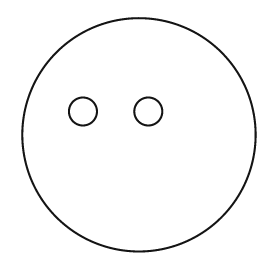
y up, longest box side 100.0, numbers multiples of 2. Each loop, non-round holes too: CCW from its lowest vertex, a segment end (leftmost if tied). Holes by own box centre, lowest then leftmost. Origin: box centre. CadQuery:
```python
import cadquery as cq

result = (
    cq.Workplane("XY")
    .moveTo(0.0, 0.0)
    .circle(50.0)
    .moveTo(-24.0, 10.0)
    .circle(6.0)
    .moveTo(4.0, 10.0)
    .circle(6.0)
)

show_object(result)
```